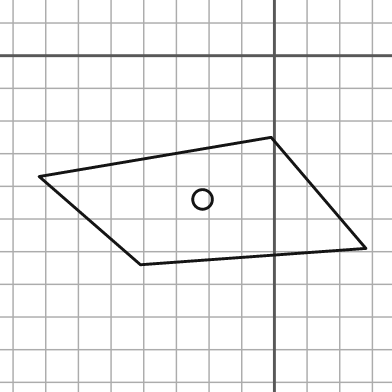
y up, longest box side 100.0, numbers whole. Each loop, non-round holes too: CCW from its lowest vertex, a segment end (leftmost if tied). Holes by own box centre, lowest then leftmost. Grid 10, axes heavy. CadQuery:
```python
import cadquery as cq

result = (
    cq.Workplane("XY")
    .moveTo(-41.0, -64.0)
    .lineTo(28.0, -59.0)
    .lineTo(-1.0, -25.0)
    .lineTo(-72.0, -37.0)
    .close()
    .moveTo(-22.0, -44.0)
    .circle(3.0)
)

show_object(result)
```